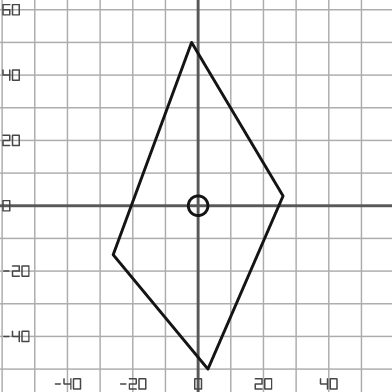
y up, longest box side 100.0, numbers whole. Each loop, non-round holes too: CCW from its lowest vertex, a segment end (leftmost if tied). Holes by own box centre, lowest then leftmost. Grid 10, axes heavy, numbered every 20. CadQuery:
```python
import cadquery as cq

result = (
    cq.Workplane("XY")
    .moveTo(3.0, -50.0)
    .lineTo(26.0, 3.0)
    .lineTo(-2.0, 50.0)
    .lineTo(-26.0, -15.0)
    .close()
    .moveTo(0.0, 0.0)
    .circle(3.0)
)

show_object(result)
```